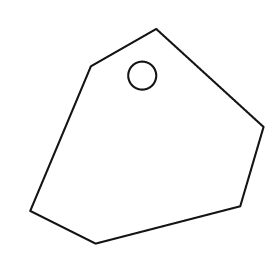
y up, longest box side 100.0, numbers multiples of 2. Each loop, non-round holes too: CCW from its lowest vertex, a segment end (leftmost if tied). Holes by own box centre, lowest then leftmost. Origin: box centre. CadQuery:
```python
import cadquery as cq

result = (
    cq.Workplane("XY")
    .moveTo(-22.0, -46.0)
    .lineTo(40.0, -30.0)
    .lineTo(50.0, 4.0)
    .lineTo(4.0, 46.0)
    .lineTo(-24.0, 30.0)
    .lineTo(-50.0, -32.0)
    .close()
    .moveTo(-2.0, 26.0)
    .circle(6.0)
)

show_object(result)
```